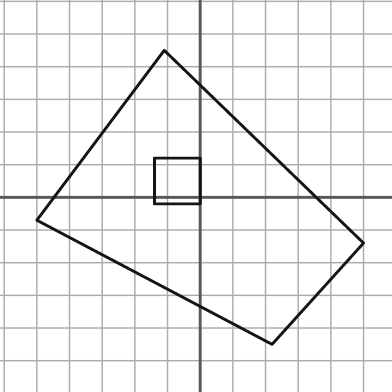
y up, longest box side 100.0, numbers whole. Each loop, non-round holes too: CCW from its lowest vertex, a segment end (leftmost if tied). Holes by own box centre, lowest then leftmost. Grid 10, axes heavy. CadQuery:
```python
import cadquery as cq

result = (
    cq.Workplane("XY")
    .moveTo(22.0, -45.0)
    .lineTo(50.0, -14.0)
    .lineTo(-11.0, 45.0)
    .lineTo(-50.0, -7.0)
    .close()
    .moveTo(-14.0, -2.0)
    .lineTo(0.0, -2.0)
    .lineTo(0.0, 12.0)
    .lineTo(-14.0, 12.0)
    .close()
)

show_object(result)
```